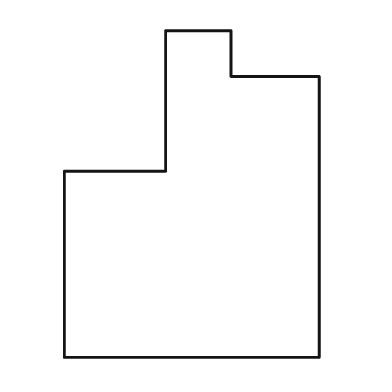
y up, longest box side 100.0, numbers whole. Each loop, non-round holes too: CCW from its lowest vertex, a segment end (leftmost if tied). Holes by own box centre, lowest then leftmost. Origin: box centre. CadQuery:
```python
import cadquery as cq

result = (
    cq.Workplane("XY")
    .moveTo(-39.0, -50.0)
    .lineTo(39.0, -50.0)
    .lineTo(39.0, 36.0)
    .lineTo(12.0, 36.0)
    .lineTo(12.0, 50.0)
    .lineTo(-8.0, 50.0)
    .lineTo(-8.0, 7.0)
    .lineTo(-39.0, 7.0)
    .close()
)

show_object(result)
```